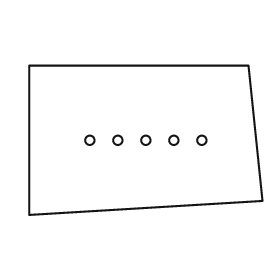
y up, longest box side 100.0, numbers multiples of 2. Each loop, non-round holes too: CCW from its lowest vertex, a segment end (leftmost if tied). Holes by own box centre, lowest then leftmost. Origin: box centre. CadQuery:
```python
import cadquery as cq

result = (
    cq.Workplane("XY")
    .moveTo(-50.0, -32.0)
    .lineTo(50.0, -26.0)
    .lineTo(44.0, 32.0)
    .lineTo(-50.0, 32.0)
    .close()
    .moveTo(-24.0, 0.0)
    .circle(2.0)
    .moveTo(-12.0, 0.0)
    .circle(2.0)
    .moveTo(0.0, 0.0)
    .circle(2.0)
    .moveTo(12.0, 0.0)
    .circle(2.0)
    .moveTo(24.0, 0.0)
    .circle(2.0)
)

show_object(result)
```